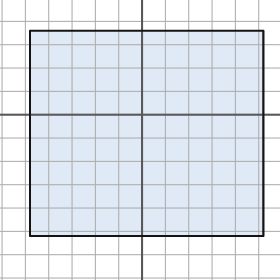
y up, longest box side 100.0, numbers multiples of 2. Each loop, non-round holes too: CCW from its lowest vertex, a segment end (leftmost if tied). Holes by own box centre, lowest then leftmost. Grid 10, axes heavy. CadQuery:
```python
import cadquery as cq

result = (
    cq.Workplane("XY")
    .moveTo(-48.0, -52.0)
    .lineTo(52.0, -52.0)
    .lineTo(52.0, 36.0)
    .lineTo(-48.0, 36.0)
    .close()
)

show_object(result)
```